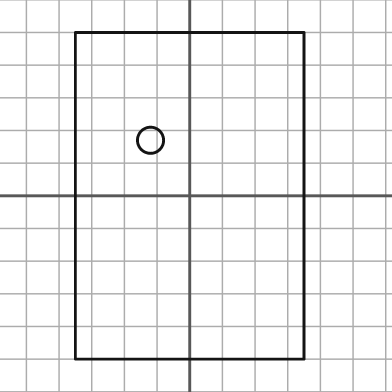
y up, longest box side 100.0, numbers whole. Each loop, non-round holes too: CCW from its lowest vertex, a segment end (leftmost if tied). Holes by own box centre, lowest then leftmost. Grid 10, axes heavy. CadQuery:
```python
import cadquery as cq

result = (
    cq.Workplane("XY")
    .moveTo(-35.0, -50.0)
    .lineTo(35.0, -50.0)
    .lineTo(35.0, 50.0)
    .lineTo(-35.0, 50.0)
    .close()
    .moveTo(-12.0, 17.0)
    .circle(4.0)
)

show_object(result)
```